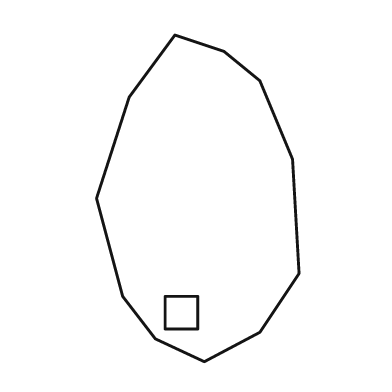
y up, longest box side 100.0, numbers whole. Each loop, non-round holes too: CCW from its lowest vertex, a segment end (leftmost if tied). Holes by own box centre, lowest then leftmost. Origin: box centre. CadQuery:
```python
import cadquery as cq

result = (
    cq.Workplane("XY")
    .moveTo(2.0, -50.0)
    .lineTo(19.0, -41.0)
    .lineTo(31.0, -23.0)
    .lineTo(29.0, 12.0)
    .lineTo(19.0, 36.0)
    .lineTo(8.0, 45.0)
    .lineTo(-7.0, 50.0)
    .lineTo(-21.0, 31.0)
    .lineTo(-31.0, 0.0)
    .lineTo(-23.0, -30.0)
    .lineTo(-13.0, -43.0)
    .close()
    .moveTo(-10.0, -40.0)
    .lineTo(0.0, -40.0)
    .lineTo(0.0, -30.0)
    .lineTo(-10.0, -30.0)
    .close()
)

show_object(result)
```